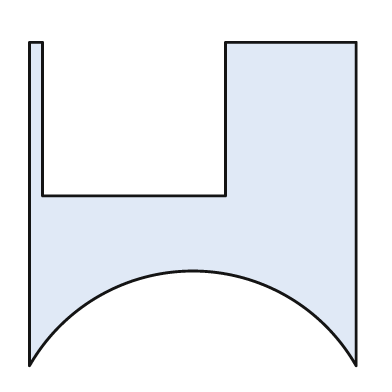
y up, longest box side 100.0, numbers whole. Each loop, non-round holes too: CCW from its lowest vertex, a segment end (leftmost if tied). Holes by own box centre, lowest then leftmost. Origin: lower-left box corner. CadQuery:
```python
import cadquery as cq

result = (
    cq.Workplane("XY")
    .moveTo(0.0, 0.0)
    .threePointArc((50.0, 29.0), (100.0, 0.0))
    .lineTo(100.0, 99.0)
    .lineTo(60.0, 99.0)
    .lineTo(60.0, 52.0)
    .lineTo(4.0, 52.0)
    .lineTo(4.0, 99.0)
    .lineTo(0.0, 99.0)
    .close()
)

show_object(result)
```